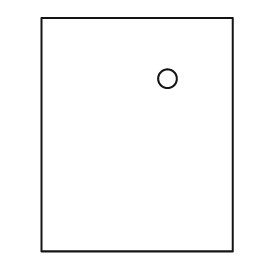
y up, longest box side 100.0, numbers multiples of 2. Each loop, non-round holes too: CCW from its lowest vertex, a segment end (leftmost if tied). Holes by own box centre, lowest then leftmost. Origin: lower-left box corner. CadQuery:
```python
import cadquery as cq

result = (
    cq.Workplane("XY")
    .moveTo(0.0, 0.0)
    .lineTo(82.0, 0.0)
    .lineTo(82.0, 100.0)
    .lineTo(0.0, 100.0)
    .close()
    .moveTo(54.0, 74.0)
    .circle(4.0)
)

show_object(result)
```